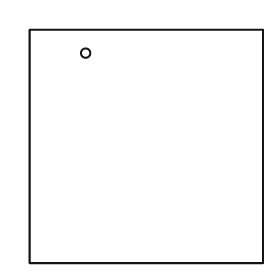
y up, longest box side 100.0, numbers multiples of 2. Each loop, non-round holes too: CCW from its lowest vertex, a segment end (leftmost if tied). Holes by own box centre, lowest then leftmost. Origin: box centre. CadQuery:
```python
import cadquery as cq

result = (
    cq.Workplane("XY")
    .moveTo(-50.0, -50.0)
    .lineTo(50.0, -50.0)
    .lineTo(50.0, 50.0)
    .lineTo(-50.0, 50.0)
    .close()
    .moveTo(-26.0, 40.0)
    .circle(2.0)
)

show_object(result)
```